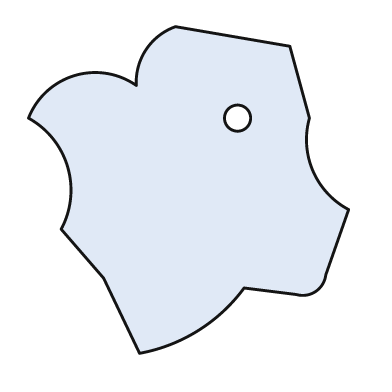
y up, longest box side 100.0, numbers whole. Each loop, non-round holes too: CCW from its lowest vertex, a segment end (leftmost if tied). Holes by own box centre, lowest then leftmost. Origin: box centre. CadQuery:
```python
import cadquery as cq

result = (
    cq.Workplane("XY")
    .moveTo(-15.0, -50.0)
    .threePointArc((3.0, -43.0), (17.0, -30.0))
    .lineTo(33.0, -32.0)
    .threePointArc((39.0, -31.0), (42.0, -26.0))
    .lineTo(49.0, -6.0)
    .threePointArc((38.0, 6.0), (37.0, 22.0))
    .lineTo(31.0, 44.0)
    .lineTo(-4.0, 50.0)
    .threePointArc((-13.0, 43.0), (-16.0, 32.0))
    .threePointArc((-35.0, 35.0), (-49.0, 22.0))
    .threePointArc((-37.0, 7.0), (-39.0, -12.0))
    .lineTo(-26.0, -27.0)
    .close()
    .moveTo(15.0, 22.0)
    .circle(4.0)
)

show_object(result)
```